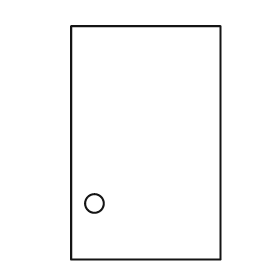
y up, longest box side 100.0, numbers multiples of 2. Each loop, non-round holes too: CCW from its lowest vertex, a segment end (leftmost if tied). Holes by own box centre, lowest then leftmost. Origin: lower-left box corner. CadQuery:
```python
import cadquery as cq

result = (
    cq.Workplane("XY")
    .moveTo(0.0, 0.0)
    .lineTo(64.0, 0.0)
    .lineTo(64.0, 100.0)
    .lineTo(0.0, 100.0)
    .close()
    .moveTo(10.0, 24.0)
    .circle(4.0)
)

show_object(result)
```